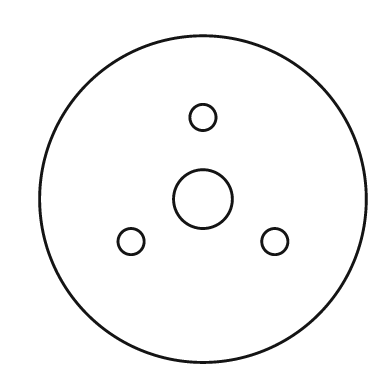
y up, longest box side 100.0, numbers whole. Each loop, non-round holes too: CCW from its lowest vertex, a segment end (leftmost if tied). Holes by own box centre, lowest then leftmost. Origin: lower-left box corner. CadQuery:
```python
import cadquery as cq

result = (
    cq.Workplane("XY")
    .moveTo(50.0, 50.0)
    .circle(50.0)
    .moveTo(28.0, 37.0)
    .circle(4.0)
    .moveTo(72.0, 37.0)
    .circle(4.0)
    .moveTo(50.0, 50.0)
    .circle(9.0)
    .moveTo(50.0, 75.0)
    .circle(4.0)
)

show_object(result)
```